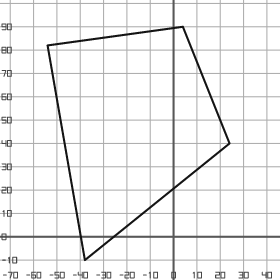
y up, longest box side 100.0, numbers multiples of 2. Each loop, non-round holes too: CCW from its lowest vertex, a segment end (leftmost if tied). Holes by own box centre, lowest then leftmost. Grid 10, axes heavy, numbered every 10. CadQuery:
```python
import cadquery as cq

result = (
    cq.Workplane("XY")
    .moveTo(-38.0, -10.0)
    .lineTo(24.0, 40.0)
    .lineTo(4.0, 90.0)
    .lineTo(-54.0, 82.0)
    .close()
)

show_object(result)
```